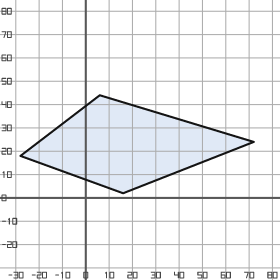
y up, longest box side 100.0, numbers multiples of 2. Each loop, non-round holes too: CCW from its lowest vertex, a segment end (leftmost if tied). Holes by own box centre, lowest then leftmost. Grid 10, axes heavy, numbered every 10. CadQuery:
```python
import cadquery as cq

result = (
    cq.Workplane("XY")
    .moveTo(16.0, 2.0)
    .lineTo(72.0, 24.0)
    .lineTo(6.0, 44.0)
    .lineTo(-28.0, 18.0)
    .close()
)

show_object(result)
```